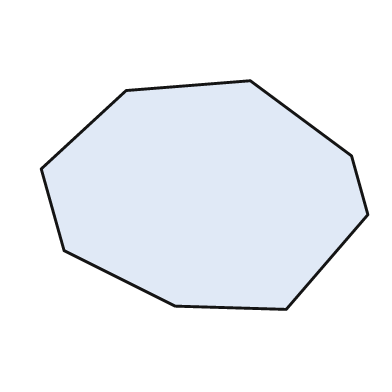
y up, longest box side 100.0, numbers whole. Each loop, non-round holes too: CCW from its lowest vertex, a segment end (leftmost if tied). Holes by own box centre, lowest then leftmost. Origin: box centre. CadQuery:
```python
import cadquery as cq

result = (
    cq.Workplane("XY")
    .moveTo(25.0, -35.0)
    .lineTo(50.0, -6.0)
    .lineTo(45.0, 12.0)
    .lineTo(14.0, 35.0)
    .lineTo(-24.0, 32.0)
    .lineTo(-50.0, 8.0)
    .lineTo(-43.0, -17.0)
    .lineTo(-9.0, -34.0)
    .close()
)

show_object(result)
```